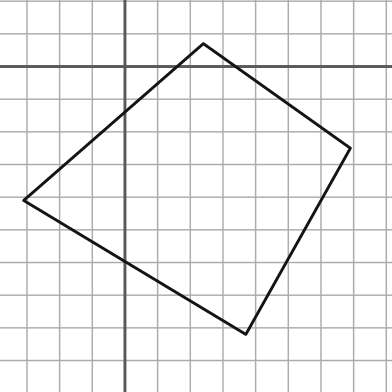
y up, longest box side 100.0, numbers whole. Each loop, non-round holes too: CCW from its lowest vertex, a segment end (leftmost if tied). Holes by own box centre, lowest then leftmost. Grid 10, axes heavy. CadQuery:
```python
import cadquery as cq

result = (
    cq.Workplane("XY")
    .moveTo(37.0, -82.0)
    .lineTo(69.0, -25.0)
    .lineTo(24.0, 7.0)
    .lineTo(-31.0, -41.0)
    .close()
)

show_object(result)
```